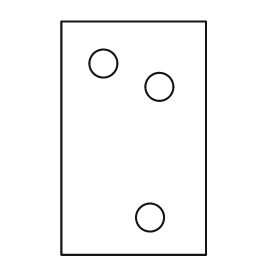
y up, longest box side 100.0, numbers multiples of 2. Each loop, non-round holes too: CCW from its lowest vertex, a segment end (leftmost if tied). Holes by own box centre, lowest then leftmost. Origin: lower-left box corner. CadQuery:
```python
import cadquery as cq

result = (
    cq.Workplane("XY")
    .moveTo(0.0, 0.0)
    .lineTo(62.0, 0.0)
    .lineTo(62.0, 100.0)
    .lineTo(0.0, 100.0)
    .close()
    .moveTo(38.0, 16.0)
    .circle(6.0)
    .moveTo(42.0, 72.0)
    .circle(6.0)
    .moveTo(18.0, 82.0)
    .circle(6.0)
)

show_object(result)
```